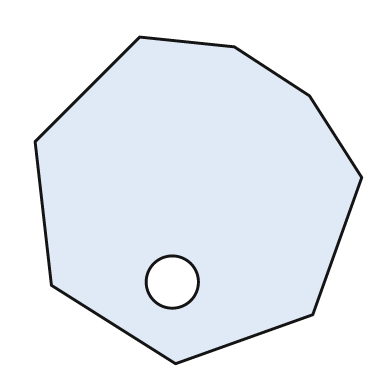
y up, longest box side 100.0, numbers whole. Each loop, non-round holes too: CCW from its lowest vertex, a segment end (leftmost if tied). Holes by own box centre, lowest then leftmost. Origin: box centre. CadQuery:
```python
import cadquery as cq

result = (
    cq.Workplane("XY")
    .moveTo(-7.0, -50.0)
    .lineTo(35.0, -35.0)
    .lineTo(50.0, 7.0)
    .lineTo(34.0, 32.0)
    .lineTo(11.0, 47.0)
    .lineTo(-18.0, 50.0)
    .lineTo(-50.0, 18.0)
    .lineTo(-45.0, -26.0)
    .close()
    .moveTo(-8.0, -25.0)
    .circle(8.0)
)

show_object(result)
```